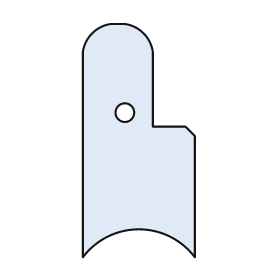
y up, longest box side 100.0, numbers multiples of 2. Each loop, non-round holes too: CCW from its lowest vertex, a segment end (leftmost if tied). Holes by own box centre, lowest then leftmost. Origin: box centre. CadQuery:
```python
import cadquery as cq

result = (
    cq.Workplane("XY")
    .moveTo(-24.0, -50.0)
    .threePointArc((0.0, -38.0), (24.0, -50.0))
    .lineTo(24.0, 2.0)
    .lineTo(20.0, 6.0)
    .lineTo(6.0, 6.0)
    .lineTo(6.0, 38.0)
    .threePointArc((2.0, 46.0), (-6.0, 50.0))
    .lineTo(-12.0, 50.0)
    .threePointArc((-20.0, 46.0), (-24.0, 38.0))
    .close()
    .moveTo(-6.0, 12.0)
    .circle(4.0)
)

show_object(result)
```